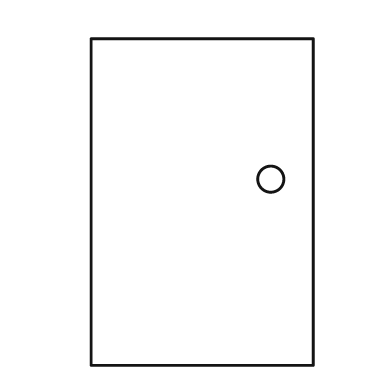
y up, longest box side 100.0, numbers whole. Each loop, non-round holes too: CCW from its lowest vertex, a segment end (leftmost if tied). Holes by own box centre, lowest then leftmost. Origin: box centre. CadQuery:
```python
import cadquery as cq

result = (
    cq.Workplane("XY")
    .moveTo(-34.0, -50.0)
    .lineTo(34.0, -50.0)
    .lineTo(34.0, 50.0)
    .lineTo(-34.0, 50.0)
    .close()
    .moveTo(21.0, 7.0)
    .circle(4.0)
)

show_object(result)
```